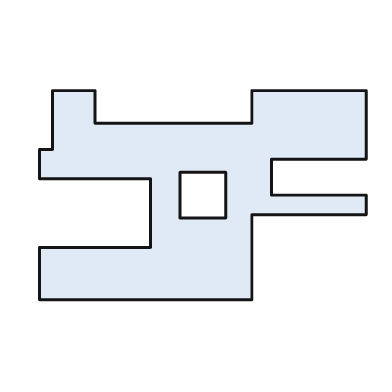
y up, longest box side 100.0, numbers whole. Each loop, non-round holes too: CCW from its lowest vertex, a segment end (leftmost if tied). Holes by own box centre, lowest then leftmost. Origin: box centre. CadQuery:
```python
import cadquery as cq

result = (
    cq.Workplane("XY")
    .moveTo(-50.0, -32.0)
    .lineTo(15.0, -32.0)
    .lineTo(15.0, -6.0)
    .lineTo(50.0, -6.0)
    .lineTo(50.0, 0.0)
    .lineTo(21.0, 0.0)
    .lineTo(21.0, 11.0)
    .lineTo(50.0, 11.0)
    .lineTo(50.0, 32.0)
    .lineTo(15.0, 32.0)
    .lineTo(15.0, 22.0)
    .lineTo(-33.0, 22.0)
    .lineTo(-33.0, 32.0)
    .lineTo(-46.0, 32.0)
    .lineTo(-46.0, 14.0)
    .lineTo(-50.0, 14.0)
    .lineTo(-50.0, 5.0)
    .lineTo(-16.0, 5.0)
    .lineTo(-16.0, -16.0)
    .lineTo(-50.0, -16.0)
    .close()
    .moveTo(-7.0, -7.0)
    .lineTo(7.0, -7.0)
    .lineTo(7.0, 7.0)
    .lineTo(-7.0, 7.0)
    .close()
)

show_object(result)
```